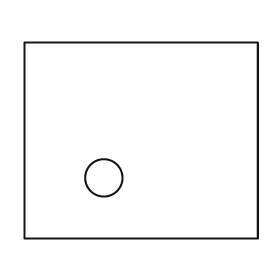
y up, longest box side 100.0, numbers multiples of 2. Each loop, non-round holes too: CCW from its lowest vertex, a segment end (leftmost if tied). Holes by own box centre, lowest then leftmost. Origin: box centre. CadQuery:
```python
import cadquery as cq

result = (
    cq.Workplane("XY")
    .moveTo(-50.0, -42.0)
    .lineTo(50.0, -42.0)
    .lineTo(50.0, 42.0)
    .lineTo(-50.0, 42.0)
    .close()
    .moveTo(-16.0, -16.0)
    .circle(8.0)
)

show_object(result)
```